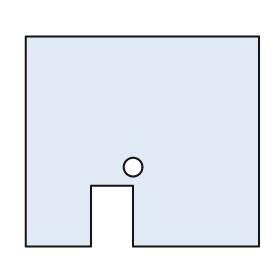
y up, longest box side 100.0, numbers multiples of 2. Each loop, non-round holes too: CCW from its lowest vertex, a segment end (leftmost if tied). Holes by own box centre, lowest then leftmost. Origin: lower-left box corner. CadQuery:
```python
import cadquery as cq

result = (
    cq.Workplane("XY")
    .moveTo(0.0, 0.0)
    .lineTo(28.0, 0.0)
    .lineTo(28.0, 26.0)
    .lineTo(46.0, 26.0)
    .lineTo(46.0, 0.0)
    .lineTo(100.0, 0.0)
    .lineTo(100.0, 90.0)
    .lineTo(0.0, 90.0)
    .close()
    .moveTo(46.0, 34.0)
    .circle(4.0)
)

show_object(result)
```